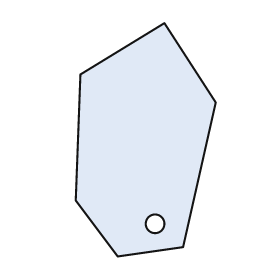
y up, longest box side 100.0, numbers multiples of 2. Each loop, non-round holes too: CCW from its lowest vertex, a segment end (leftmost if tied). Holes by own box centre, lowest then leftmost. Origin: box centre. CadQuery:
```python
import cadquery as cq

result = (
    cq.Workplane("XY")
    .moveTo(-12.0, -50.0)
    .lineTo(16.0, -46.0)
    .lineTo(30.0, 16.0)
    .lineTo(8.0, 50.0)
    .lineTo(-28.0, 28.0)
    .lineTo(-30.0, -26.0)
    .close()
    .moveTo(4.0, -36.0)
    .circle(4.0)
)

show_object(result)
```